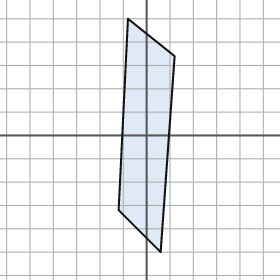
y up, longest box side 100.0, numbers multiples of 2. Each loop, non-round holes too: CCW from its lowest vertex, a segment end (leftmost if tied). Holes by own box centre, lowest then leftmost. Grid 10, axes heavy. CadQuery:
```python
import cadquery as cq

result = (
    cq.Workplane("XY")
    .moveTo(6.0, -50.0)
    .lineTo(12.0, 34.0)
    .lineTo(-8.0, 50.0)
    .lineTo(-12.0, -32.0)
    .close()
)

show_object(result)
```